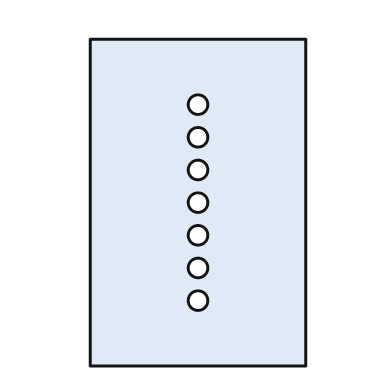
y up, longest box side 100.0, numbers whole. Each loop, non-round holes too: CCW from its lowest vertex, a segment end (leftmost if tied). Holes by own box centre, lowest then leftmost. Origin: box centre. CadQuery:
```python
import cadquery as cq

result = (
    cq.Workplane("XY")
    .moveTo(-33.0, -50.0)
    .lineTo(33.0, -50.0)
    .lineTo(33.0, 50.0)
    .lineTo(-33.0, 50.0)
    .close()
    .moveTo(0.0, -30.0)
    .circle(3.0)
    .moveTo(0.0, -20.0)
    .circle(3.0)
    .moveTo(0.0, -10.0)
    .circle(3.0)
    .moveTo(0.0, 0.0)
    .circle(3.0)
    .moveTo(0.0, 10.0)
    .circle(3.0)
    .moveTo(0.0, 20.0)
    .circle(3.0)
    .moveTo(0.0, 30.0)
    .circle(3.0)
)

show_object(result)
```